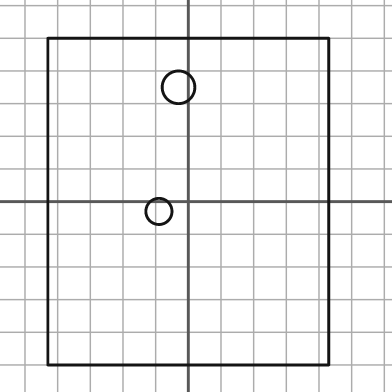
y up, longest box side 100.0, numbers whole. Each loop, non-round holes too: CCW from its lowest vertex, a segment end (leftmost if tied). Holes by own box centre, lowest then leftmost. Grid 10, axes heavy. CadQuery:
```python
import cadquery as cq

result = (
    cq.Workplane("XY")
    .moveTo(-43.0, -50.0)
    .lineTo(43.0, -50.0)
    .lineTo(43.0, 50.0)
    .lineTo(-43.0, 50.0)
    .close()
    .moveTo(-9.0, -3.0)
    .circle(4.0)
    .moveTo(-3.0, 35.0)
    .circle(5.0)
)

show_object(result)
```